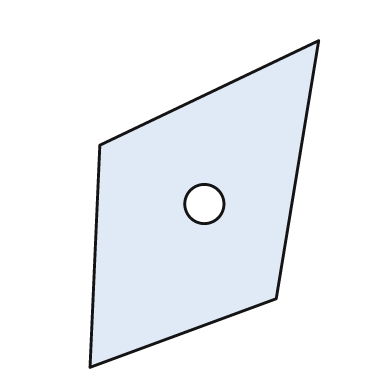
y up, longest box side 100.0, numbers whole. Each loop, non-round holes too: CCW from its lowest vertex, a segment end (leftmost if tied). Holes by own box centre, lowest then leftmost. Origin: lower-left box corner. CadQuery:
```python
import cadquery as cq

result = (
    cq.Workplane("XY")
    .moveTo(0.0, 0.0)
    .lineTo(57.0, 21.0)
    .lineTo(70.0, 100.0)
    .lineTo(3.0, 68.0)
    .close()
    .moveTo(35.0, 50.0)
    .circle(6.0)
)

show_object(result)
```